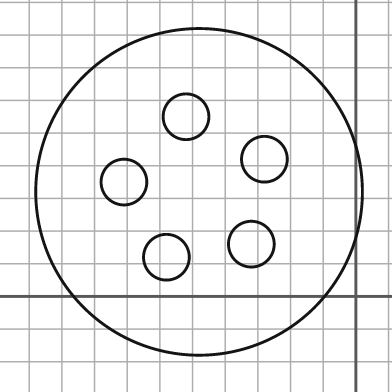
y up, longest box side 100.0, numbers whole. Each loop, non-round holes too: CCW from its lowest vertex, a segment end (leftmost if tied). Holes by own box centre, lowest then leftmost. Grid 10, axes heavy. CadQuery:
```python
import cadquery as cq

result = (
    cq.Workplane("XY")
    .moveTo(-48.0, 32.0)
    .circle(50.0)
    .moveTo(-58.0, 12.0)
    .circle(7.0)
    .moveTo(-32.0, 16.0)
    .circle(7.0)
    .moveTo(-71.0, 35.0)
    .circle(7.0)
    .moveTo(-28.0, 42.0)
    .circle(7.0)
    .moveTo(-52.0, 55.0)
    .circle(7.0)
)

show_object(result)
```